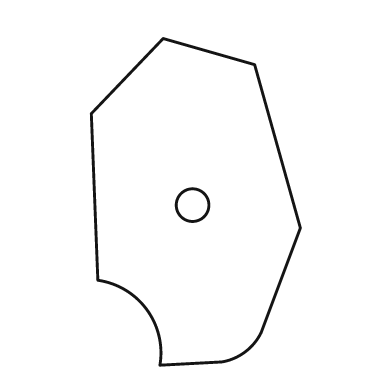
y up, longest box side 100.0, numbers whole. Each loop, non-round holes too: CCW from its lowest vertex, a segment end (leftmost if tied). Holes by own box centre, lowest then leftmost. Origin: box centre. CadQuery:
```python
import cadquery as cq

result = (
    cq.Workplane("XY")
    .moveTo(-11.0, -50.0)
    .lineTo(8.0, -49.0)
    .threePointArc((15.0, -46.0), (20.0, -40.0))
    .lineTo(32.0, -8.0)
    .lineTo(18.0, 42.0)
    .lineTo(-10.0, 50.0)
    .lineTo(-32.0, 27.0)
    .lineTo(-30.0, -24.0)
    .threePointArc((-15.0, -33.0), (-11.0, -50.0))
    .close()
    .moveTo(-1.0, -1.0)
    .circle(5.0)
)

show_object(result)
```